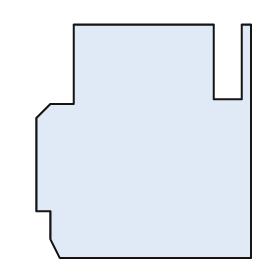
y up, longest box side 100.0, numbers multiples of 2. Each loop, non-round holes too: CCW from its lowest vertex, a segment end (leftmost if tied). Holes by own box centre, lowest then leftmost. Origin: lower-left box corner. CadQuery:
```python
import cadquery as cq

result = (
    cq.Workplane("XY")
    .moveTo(10.0, 0.0)
    .lineTo(92.0, 0.0)
    .lineTo(92.0, 100.0)
    .lineTo(88.0, 100.0)
    .lineTo(88.0, 68.0)
    .lineTo(76.0, 68.0)
    .lineTo(76.0, 100.0)
    .lineTo(16.0, 100.0)
    .lineTo(16.0, 66.0)
    .lineTo(6.0, 66.0)
    .lineTo(0.0, 60.0)
    .lineTo(0.0, 20.0)
    .lineTo(6.0, 20.0)
    .lineTo(6.0, 8.0)
    .close()
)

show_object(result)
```